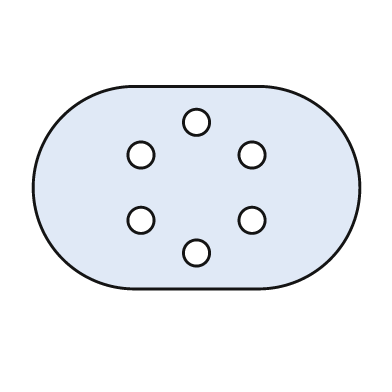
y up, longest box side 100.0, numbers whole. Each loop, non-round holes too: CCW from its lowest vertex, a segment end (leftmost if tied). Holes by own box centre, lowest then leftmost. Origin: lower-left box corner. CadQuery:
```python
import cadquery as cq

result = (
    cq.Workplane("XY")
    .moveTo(31.0, 0.0)
    .lineTo(69.0, 0.0)
    .threePointArc((100.0, 31.0), (69.0, 62.0))
    .lineTo(31.0, 62.0)
    .threePointArc((0.0, 31.0), (31.0, 0.0))
    .close()
    .moveTo(50.0, 11.0)
    .circle(4.0)
    .moveTo(33.0, 21.0)
    .circle(4.0)
    .moveTo(67.0, 21.0)
    .circle(4.0)
    .moveTo(33.0, 41.0)
    .circle(4.0)
    .moveTo(67.0, 41.0)
    .circle(4.0)
    .moveTo(50.0, 51.0)
    .circle(4.0)
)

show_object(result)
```